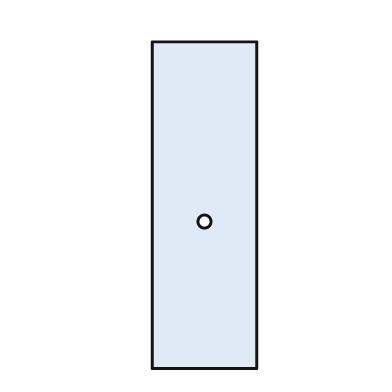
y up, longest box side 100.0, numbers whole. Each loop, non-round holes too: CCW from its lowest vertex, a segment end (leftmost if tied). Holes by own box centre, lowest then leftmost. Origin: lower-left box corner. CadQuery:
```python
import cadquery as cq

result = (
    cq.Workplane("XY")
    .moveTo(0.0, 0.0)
    .lineTo(32.0, 0.0)
    .lineTo(32.0, 100.0)
    .lineTo(0.0, 100.0)
    .close()
    .moveTo(16.0, 45.0)
    .circle(2.0)
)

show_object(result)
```